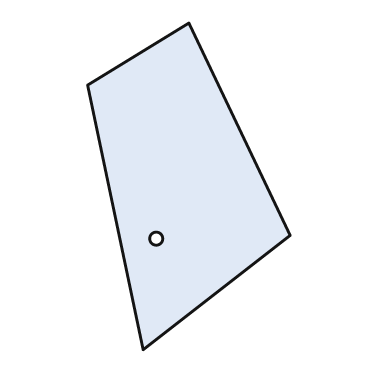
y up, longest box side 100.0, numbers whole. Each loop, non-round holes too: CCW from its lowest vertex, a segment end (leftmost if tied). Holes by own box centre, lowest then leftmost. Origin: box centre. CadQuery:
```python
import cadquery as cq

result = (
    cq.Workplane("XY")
    .moveTo(-14.0, -50.0)
    .lineTo(31.0, -15.0)
    .lineTo(0.0, 50.0)
    .lineTo(-31.0, 31.0)
    .close()
    .moveTo(-10.0, -16.0)
    .circle(2.0)
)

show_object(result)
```